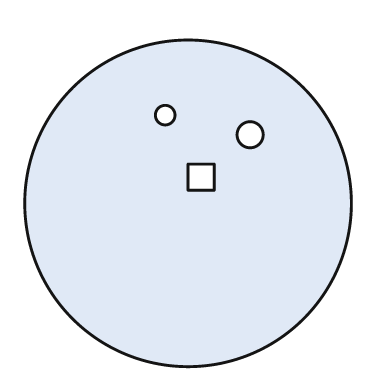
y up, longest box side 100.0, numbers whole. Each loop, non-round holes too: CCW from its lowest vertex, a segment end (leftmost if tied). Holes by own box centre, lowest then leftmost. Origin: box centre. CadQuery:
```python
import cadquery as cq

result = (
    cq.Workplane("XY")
    .moveTo(0.0, 0.0)
    .circle(50.0)
    .moveTo(0.0, 4.0)
    .lineTo(8.0, 4.0)
    .lineTo(8.0, 12.0)
    .lineTo(0.0, 12.0)
    .close()
    .moveTo(19.0, 21.0)
    .circle(4.0)
    .moveTo(-7.0, 27.0)
    .circle(3.0)
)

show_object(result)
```